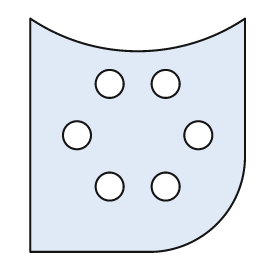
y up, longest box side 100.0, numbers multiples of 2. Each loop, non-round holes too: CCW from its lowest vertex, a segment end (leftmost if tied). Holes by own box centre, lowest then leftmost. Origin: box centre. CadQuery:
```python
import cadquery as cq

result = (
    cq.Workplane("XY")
    .moveTo(-46.0, -50.0)
    .lineTo(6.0, -50.0)
    .threePointArc((34.0, -38.0), (46.0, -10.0))
    .lineTo(46.0, 50.0)
    .threePointArc((0.0, 36.0), (-46.0, 50.0))
    .close()
    .moveTo(-12.0, -22.0)
    .circle(6.0)
    .moveTo(12.0, -22.0)
    .circle(6.0)
    .moveTo(-26.0, 0.0)
    .circle(6.0)
    .moveTo(26.0, 0.0)
    .circle(6.0)
    .moveTo(-12.0, 22.0)
    .circle(6.0)
    .moveTo(12.0, 22.0)
    .circle(6.0)
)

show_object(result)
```